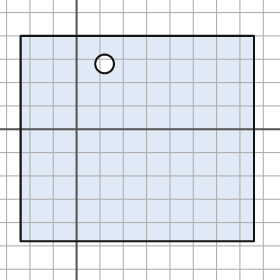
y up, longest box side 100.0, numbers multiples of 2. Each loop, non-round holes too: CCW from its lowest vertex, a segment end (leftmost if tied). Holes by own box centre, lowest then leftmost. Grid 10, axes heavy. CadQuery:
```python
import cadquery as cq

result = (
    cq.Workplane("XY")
    .moveTo(-24.0, -48.0)
    .lineTo(76.0, -48.0)
    .lineTo(76.0, 40.0)
    .lineTo(-24.0, 40.0)
    .close()
    .moveTo(12.0, 28.0)
    .circle(4.0)
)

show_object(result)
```